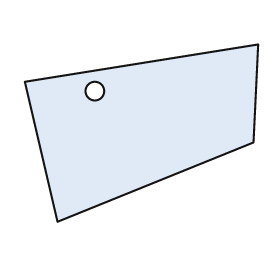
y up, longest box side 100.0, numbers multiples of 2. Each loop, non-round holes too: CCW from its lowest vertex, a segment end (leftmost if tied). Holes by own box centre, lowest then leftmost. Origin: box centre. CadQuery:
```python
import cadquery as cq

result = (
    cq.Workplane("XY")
    .moveTo(-36.0, -38.0)
    .lineTo(48.0, -4.0)
    .lineTo(50.0, 38.0)
    .lineTo(-50.0, 22.0)
    .close()
    .moveTo(-20.0, 18.0)
    .circle(4.0)
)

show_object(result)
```